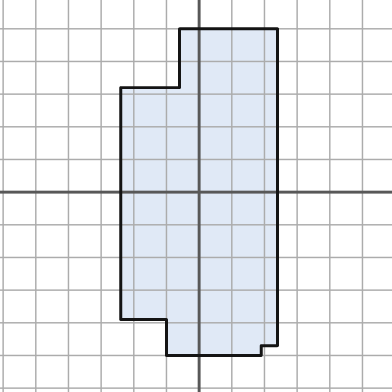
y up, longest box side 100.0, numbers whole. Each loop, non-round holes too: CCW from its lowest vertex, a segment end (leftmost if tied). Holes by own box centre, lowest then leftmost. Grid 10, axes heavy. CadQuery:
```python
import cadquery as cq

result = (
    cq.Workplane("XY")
    .moveTo(-10.0, -50.0)
    .lineTo(19.0, -50.0)
    .lineTo(19.0, -47.0)
    .lineTo(24.0, -47.0)
    .lineTo(24.0, 50.0)
    .lineTo(-6.0, 50.0)
    .lineTo(-6.0, 32.0)
    .lineTo(-24.0, 32.0)
    .lineTo(-24.0, -39.0)
    .lineTo(-10.0, -39.0)
    .close()
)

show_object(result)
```